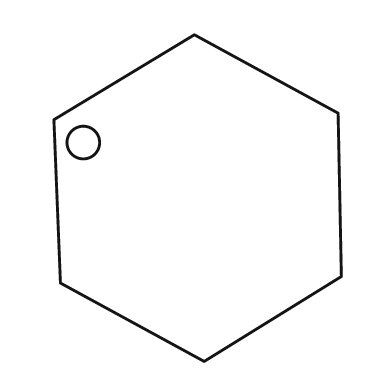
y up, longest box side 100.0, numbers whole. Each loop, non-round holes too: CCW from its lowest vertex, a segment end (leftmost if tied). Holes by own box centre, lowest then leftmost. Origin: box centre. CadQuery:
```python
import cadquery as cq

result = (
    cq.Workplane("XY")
    .moveTo(2.0, -50.0)
    .lineTo(44.0, -24.0)
    .lineTo(43.0, 26.0)
    .lineTo(-1.0, 50.0)
    .lineTo(-44.0, 24.0)
    .lineTo(-42.0, -26.0)
    .close()
    .moveTo(-35.0, 17.0)
    .circle(5.0)
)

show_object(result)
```